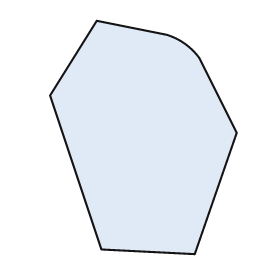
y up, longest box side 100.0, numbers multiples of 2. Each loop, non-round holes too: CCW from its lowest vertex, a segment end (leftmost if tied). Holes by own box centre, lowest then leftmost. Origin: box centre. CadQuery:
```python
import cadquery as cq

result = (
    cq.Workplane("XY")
    .moveTo(22.0, -50.0)
    .lineTo(40.0, 2.0)
    .lineTo(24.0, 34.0)
    .threePointArc((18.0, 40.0), (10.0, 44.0))
    .lineTo(-20.0, 50.0)
    .lineTo(-40.0, 18.0)
    .lineTo(-18.0, -48.0)
    .close()
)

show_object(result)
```